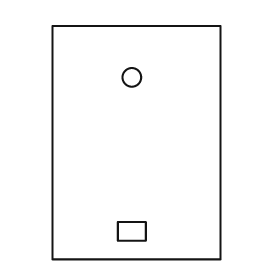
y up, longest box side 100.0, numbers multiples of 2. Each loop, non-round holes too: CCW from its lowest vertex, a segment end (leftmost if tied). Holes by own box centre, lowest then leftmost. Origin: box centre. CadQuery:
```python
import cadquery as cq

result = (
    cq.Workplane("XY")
    .moveTo(-36.0, -50.0)
    .lineTo(36.0, -50.0)
    .lineTo(36.0, 50.0)
    .lineTo(-36.0, 50.0)
    .close()
    .moveTo(-8.0, -42.0)
    .lineTo(4.0, -42.0)
    .lineTo(4.0, -34.0)
    .lineTo(-8.0, -34.0)
    .close()
    .moveTo(-2.0, 28.0)
    .circle(4.0)
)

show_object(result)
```